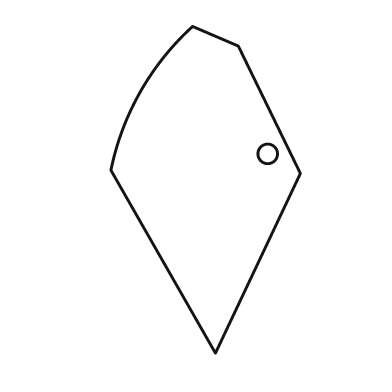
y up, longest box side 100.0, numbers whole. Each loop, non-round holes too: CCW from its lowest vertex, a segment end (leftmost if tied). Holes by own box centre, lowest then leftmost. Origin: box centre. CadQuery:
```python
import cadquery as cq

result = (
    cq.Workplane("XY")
    .moveTo(3.0, -50.0)
    .lineTo(29.0, 5.0)
    .lineTo(10.0, 44.0)
    .lineTo(-4.0, 50.0)
    .threePointArc((-20.0, 30.0), (-29.0, 6.0))
    .close()
    .moveTo(19.0, 11.0)
    .circle(3.0)
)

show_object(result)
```